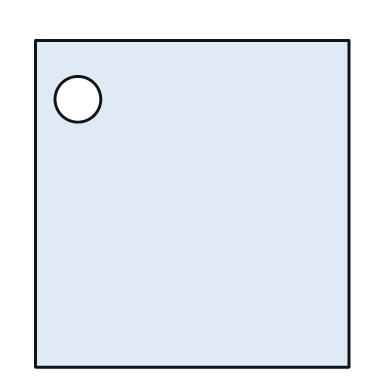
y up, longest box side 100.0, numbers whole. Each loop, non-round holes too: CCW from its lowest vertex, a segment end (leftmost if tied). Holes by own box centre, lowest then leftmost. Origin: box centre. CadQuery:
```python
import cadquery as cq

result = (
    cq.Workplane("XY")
    .moveTo(-48.0, -50.0)
    .lineTo(48.0, -50.0)
    .lineTo(48.0, 50.0)
    .lineTo(-48.0, 50.0)
    .close()
    .moveTo(-35.0, 32.0)
    .circle(7.0)
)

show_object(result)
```